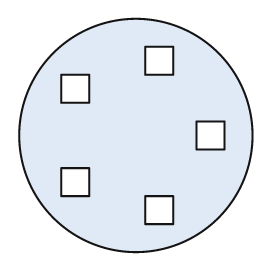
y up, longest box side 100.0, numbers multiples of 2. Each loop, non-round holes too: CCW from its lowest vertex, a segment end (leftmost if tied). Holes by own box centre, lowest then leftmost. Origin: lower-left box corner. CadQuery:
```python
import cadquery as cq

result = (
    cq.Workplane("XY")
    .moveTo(50.0, 50.0)
    .circle(50.0)
    .moveTo(54.0, 12.0)
    .lineTo(66.0, 12.0)
    .lineTo(66.0, 24.0)
    .lineTo(54.0, 24.0)
    .close()
    .moveTo(18.0, 24.0)
    .lineTo(30.0, 24.0)
    .lineTo(30.0, 36.0)
    .lineTo(18.0, 36.0)
    .close()
    .moveTo(76.0, 44.0)
    .lineTo(88.0, 44.0)
    .lineTo(88.0, 56.0)
    .lineTo(76.0, 56.0)
    .close()
    .moveTo(18.0, 64.0)
    .lineTo(30.0, 64.0)
    .lineTo(30.0, 76.0)
    .lineTo(18.0, 76.0)
    .close()
    .moveTo(54.0, 76.0)
    .lineTo(66.0, 76.0)
    .lineTo(66.0, 88.0)
    .lineTo(54.0, 88.0)
    .close()
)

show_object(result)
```